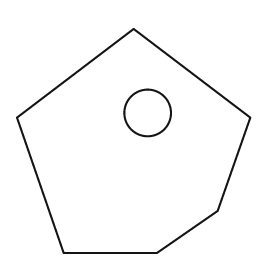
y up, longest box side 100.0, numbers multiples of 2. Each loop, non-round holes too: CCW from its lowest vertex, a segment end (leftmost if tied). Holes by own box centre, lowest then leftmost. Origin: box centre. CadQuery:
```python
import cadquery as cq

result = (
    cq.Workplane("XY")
    .moveTo(-30.0, -48.0)
    .lineTo(10.0, -48.0)
    .lineTo(36.0, -30.0)
    .lineTo(50.0, 10.0)
    .lineTo(0.0, 48.0)
    .lineTo(-50.0, 10.0)
    .close()
    .moveTo(6.0, 12.0)
    .circle(10.0)
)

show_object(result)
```